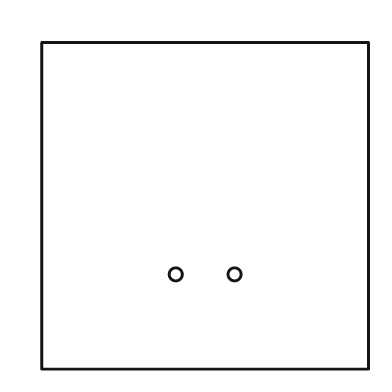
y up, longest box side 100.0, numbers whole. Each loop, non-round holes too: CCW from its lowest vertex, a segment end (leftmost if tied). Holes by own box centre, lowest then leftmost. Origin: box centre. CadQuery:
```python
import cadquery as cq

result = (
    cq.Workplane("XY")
    .moveTo(-50.0, -50.0)
    .lineTo(50.0, -50.0)
    .lineTo(50.0, 50.0)
    .lineTo(-50.0, 50.0)
    .close()
    .moveTo(-9.0, -21.0)
    .circle(2.0)
    .moveTo(9.0, -21.0)
    .circle(2.0)
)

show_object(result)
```